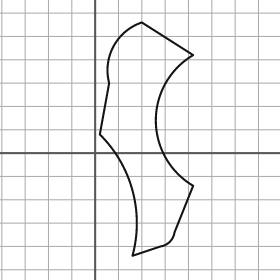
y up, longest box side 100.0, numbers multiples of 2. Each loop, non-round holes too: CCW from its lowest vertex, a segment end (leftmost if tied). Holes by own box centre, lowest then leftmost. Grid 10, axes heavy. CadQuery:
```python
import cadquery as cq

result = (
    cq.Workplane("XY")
    .moveTo(16.0, -44.0)
    .lineTo(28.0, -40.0)
    .threePointArc((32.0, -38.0), (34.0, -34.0))
    .lineTo(42.0, -14.0)
    .threePointArc((26.0, 14.0), (42.0, 42.0))
    .lineTo(20.0, 56.0)
    .threePointArc((8.0, 46.0), (6.0, 30.0))
    .lineTo(2.0, 8.0)
    .threePointArc((16.0, -16.0), (16.0, -44.0))
    .close()
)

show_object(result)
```